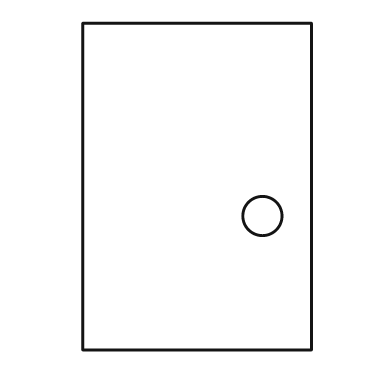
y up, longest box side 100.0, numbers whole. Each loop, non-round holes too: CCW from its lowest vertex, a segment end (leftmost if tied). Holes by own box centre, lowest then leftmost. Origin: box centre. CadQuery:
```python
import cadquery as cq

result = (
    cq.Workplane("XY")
    .moveTo(-35.0, -50.0)
    .lineTo(35.0, -50.0)
    .lineTo(35.0, 50.0)
    .lineTo(-35.0, 50.0)
    .close()
    .moveTo(20.0, -9.0)
    .circle(6.0)
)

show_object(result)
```